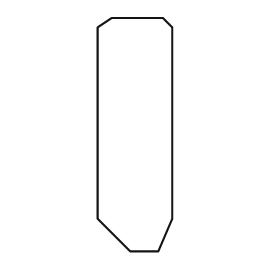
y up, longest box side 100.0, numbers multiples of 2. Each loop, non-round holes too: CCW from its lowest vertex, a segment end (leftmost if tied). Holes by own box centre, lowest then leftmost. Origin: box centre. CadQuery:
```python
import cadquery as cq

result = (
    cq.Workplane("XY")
    .moveTo(-2.0, -50.0)
    .lineTo(10.0, -50.0)
    .lineTo(16.0, -36.0)
    .lineTo(16.0, 46.0)
    .lineTo(12.0, 50.0)
    .lineTo(-10.0, 50.0)
    .lineTo(-16.0, 46.0)
    .lineTo(-16.0, -36.0)
    .close()
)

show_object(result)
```